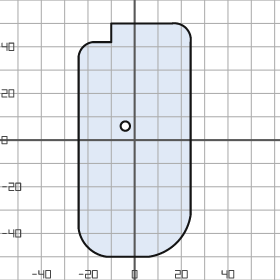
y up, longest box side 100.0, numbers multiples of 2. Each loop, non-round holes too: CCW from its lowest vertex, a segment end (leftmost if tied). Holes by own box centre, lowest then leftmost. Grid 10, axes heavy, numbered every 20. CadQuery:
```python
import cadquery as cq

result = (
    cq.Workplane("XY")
    .moveTo(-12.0, -50.0)
    .lineTo(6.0, -50.0)
    .threePointArc((18.0, -44.0), (24.0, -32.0))
    .lineTo(24.0, 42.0)
    .threePointArc((22.0, 48.0), (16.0, 50.0))
    .lineTo(-10.0, 50.0)
    .lineTo(-10.0, 42.0)
    .lineTo(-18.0, 42.0)
    .threePointArc((-22.0, 40.0), (-24.0, 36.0))
    .lineTo(-24.0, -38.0)
    .threePointArc((-20.0, -46.0), (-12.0, -50.0))
    .close()
    .moveTo(-4.0, 6.0)
    .circle(2.0)
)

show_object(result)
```